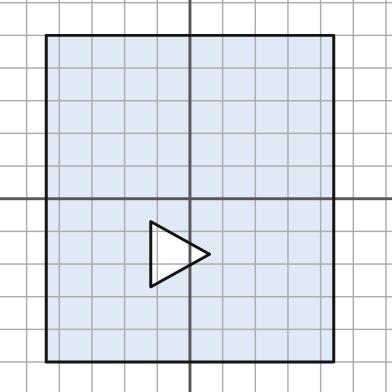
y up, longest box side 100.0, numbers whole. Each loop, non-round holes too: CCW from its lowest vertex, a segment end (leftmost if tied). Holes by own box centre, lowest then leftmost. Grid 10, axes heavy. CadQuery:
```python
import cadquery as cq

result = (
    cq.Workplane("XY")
    .moveTo(-44.0, -50.0)
    .lineTo(44.0, -50.0)
    .lineTo(44.0, 50.0)
    .lineTo(-44.0, 50.0)
    .close()
    .moveTo(-12.0, -27.0)
    .lineTo(6.0, -17.0)
    .lineTo(-12.0, -7.0)
    .close()
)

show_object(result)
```